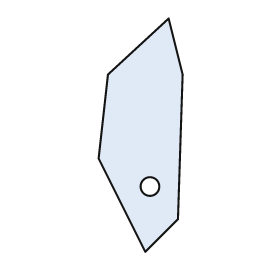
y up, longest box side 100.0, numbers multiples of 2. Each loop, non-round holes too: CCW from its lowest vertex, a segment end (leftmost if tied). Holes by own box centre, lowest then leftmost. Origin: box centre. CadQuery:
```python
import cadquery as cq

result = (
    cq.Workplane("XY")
    .moveTo(2.0, -50.0)
    .lineTo(16.0, -36.0)
    .lineTo(18.0, 26.0)
    .lineTo(12.0, 50.0)
    .lineTo(-14.0, 26.0)
    .lineTo(-18.0, -10.0)
    .close()
    .moveTo(4.0, -22.0)
    .circle(4.0)
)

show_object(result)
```